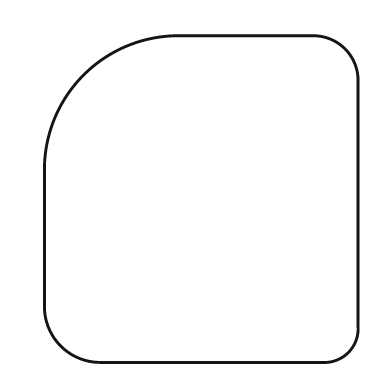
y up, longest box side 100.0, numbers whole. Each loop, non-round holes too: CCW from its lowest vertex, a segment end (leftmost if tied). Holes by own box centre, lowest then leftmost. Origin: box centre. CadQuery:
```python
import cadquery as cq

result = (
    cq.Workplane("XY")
    .moveTo(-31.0, -50.0)
    .lineTo(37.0, -50.0)
    .threePointArc((45.0, -47.0), (48.0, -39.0))
    .lineTo(48.0, 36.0)
    .threePointArc((44.0, 46.0), (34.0, 50.0))
    .lineTo(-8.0, 50.0)
    .threePointArc((-36.0, 38.0), (-48.0, 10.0))
    .lineTo(-48.0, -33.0)
    .threePointArc((-43.0, -45.0), (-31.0, -50.0))
    .close()
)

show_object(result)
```